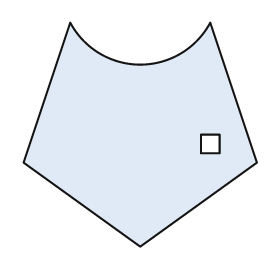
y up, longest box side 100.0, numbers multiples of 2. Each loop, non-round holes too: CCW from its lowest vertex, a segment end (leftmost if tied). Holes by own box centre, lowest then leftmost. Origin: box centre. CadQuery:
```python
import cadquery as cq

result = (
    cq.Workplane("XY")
    .moveTo(0.0, -48.0)
    .lineTo(50.0, -12.0)
    .lineTo(30.0, 48.0)
    .threePointArc((0.0, 30.0), (-30.0, 48.0))
    .lineTo(-50.0, -12.0)
    .close()
    .moveTo(26.0, -8.0)
    .lineTo(34.0, -8.0)
    .lineTo(34.0, 0.0)
    .lineTo(26.0, 0.0)
    .close()
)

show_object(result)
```